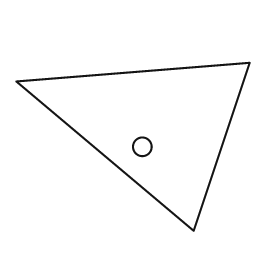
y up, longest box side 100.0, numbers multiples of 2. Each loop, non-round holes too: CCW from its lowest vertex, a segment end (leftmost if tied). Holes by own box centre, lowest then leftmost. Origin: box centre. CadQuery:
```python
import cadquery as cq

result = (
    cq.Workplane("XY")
    .moveTo(26.0, -36.0)
    .lineTo(50.0, 36.0)
    .lineTo(-50.0, 28.0)
    .close()
    .moveTo(4.0, 0.0)
    .circle(4.0)
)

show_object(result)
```